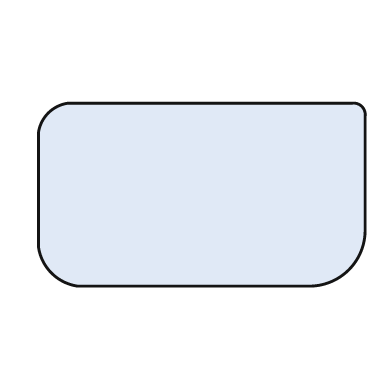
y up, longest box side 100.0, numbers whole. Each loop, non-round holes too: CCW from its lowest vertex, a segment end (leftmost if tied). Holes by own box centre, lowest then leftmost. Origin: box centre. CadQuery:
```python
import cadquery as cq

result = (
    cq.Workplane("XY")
    .moveTo(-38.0, -28.0)
    .lineTo(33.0, -28.0)
    .threePointArc((45.0, -23.0), (50.0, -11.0))
    .lineTo(50.0, 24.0)
    .threePointArc((49.0, 27.0), (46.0, 28.0))
    .lineTo(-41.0, 28.0)
    .threePointArc((-47.0, 25.0), (-50.0, 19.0))
    .lineTo(-50.0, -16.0)
    .threePointArc((-46.0, -24.0), (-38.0, -28.0))
    .close()
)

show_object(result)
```